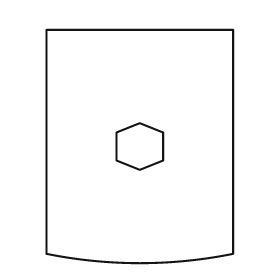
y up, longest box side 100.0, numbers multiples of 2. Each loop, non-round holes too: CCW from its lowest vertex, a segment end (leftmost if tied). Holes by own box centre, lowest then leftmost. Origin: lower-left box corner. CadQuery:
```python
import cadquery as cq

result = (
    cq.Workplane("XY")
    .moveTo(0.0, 4.0)
    .threePointArc((40.0, 0.0), (80.0, 4.0))
    .lineTo(80.0, 100.0)
    .lineTo(0.0, 100.0)
    .close()
    .moveTo(40.0, 40.0)
    .lineTo(50.0, 44.0)
    .lineTo(50.0, 56.0)
    .lineTo(40.0, 60.0)
    .lineTo(30.0, 56.0)
    .lineTo(30.0, 44.0)
    .close()
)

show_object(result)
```